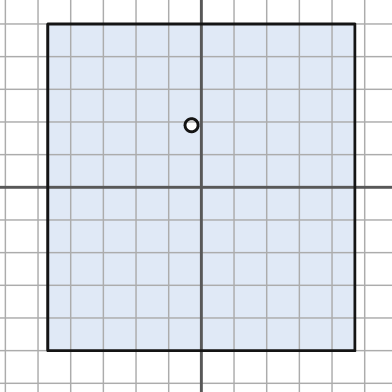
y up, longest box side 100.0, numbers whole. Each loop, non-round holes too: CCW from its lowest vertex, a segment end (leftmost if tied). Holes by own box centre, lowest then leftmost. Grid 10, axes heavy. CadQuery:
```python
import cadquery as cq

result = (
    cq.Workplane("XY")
    .moveTo(-47.0, -50.0)
    .lineTo(47.0, -50.0)
    .lineTo(47.0, 50.0)
    .lineTo(-47.0, 50.0)
    .close()
    .moveTo(-3.0, 19.0)
    .circle(2.0)
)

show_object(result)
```